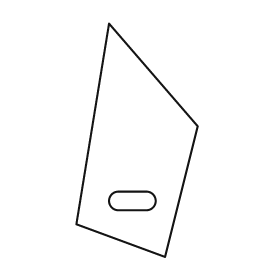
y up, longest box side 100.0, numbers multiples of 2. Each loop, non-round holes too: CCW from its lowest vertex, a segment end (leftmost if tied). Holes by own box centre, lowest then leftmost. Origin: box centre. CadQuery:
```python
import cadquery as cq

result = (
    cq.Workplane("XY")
    .moveTo(12.0, -50.0)
    .lineTo(26.0, 6.0)
    .lineTo(-12.0, 50.0)
    .lineTo(-26.0, -36.0)
    .close()
    .moveTo(-8.0, -30.0)
    .lineTo(4.0, -30.0)
    .threePointArc((8.0, -26.0), (4.0, -22.0))
    .lineTo(-8.0, -22.0)
    .threePointArc((-12.0, -26.0), (-8.0, -30.0))
    .close()
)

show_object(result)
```